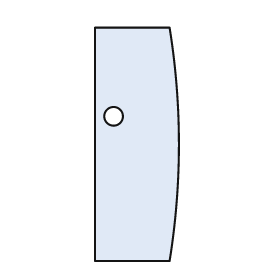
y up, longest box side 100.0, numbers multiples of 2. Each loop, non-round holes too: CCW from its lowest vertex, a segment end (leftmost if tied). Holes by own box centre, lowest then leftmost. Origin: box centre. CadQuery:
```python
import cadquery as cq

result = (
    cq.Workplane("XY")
    .moveTo(-18.0, -50.0)
    .lineTo(14.0, -50.0)
    .threePointArc((18.0, 0.0), (14.0, 50.0))
    .lineTo(-18.0, 50.0)
    .close()
    .moveTo(-10.0, 12.0)
    .circle(4.0)
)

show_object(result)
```